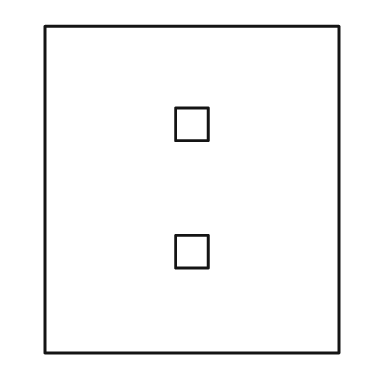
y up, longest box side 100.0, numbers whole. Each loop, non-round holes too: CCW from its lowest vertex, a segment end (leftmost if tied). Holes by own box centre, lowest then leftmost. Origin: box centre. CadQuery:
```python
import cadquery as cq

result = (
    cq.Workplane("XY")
    .moveTo(-45.0, -50.0)
    .lineTo(45.0, -50.0)
    .lineTo(45.0, 50.0)
    .lineTo(-45.0, 50.0)
    .close()
    .moveTo(-5.0, -24.0)
    .lineTo(5.0, -24.0)
    .lineTo(5.0, -14.0)
    .lineTo(-5.0, -14.0)
    .close()
    .moveTo(-5.0, 15.0)
    .lineTo(5.0, 15.0)
    .lineTo(5.0, 25.0)
    .lineTo(-5.0, 25.0)
    .close()
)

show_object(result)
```